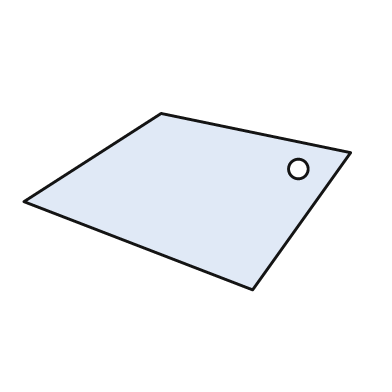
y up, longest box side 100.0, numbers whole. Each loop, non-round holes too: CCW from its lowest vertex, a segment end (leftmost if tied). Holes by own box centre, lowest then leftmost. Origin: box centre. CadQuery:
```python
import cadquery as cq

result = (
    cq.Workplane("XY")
    .moveTo(20.0, -27.0)
    .lineTo(50.0, 15.0)
    .lineTo(-8.0, 27.0)
    .lineTo(-50.0, 0.0)
    .close()
    .moveTo(34.0, 10.0)
    .circle(3.0)
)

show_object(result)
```